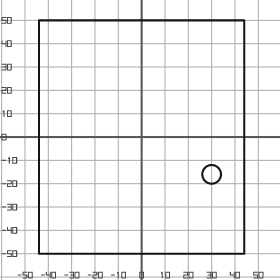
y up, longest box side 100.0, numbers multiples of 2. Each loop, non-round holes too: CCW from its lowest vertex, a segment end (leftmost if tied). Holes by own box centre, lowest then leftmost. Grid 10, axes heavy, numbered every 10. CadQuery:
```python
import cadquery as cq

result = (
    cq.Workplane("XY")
    .moveTo(-44.0, -50.0)
    .lineTo(44.0, -50.0)
    .lineTo(44.0, 50.0)
    .lineTo(-44.0, 50.0)
    .close()
    .moveTo(30.0, -16.0)
    .circle(4.0)
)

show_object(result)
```